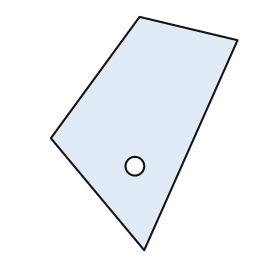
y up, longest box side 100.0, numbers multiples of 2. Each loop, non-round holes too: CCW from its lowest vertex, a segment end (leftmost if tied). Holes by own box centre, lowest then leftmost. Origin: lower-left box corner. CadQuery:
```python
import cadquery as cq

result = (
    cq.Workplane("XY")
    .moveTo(40.0, 0.0)
    .lineTo(80.0, 90.0)
    .lineTo(38.0, 100.0)
    .lineTo(0.0, 48.0)
    .close()
    .moveTo(36.0, 36.0)
    .circle(4.0)
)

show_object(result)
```